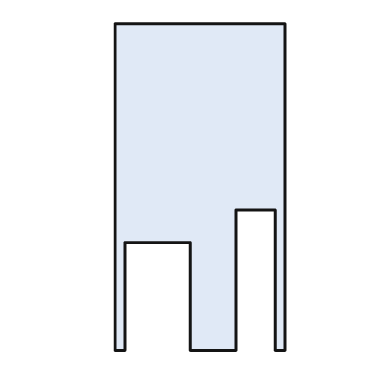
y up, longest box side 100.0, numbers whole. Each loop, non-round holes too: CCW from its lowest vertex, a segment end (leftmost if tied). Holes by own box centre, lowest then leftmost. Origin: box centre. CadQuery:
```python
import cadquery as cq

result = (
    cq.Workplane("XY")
    .moveTo(-26.0, -50.0)
    .lineTo(-23.0, -50.0)
    .lineTo(-23.0, -17.0)
    .lineTo(-3.0, -17.0)
    .lineTo(-3.0, -50.0)
    .lineTo(11.0, -50.0)
    .lineTo(11.0, -7.0)
    .lineTo(23.0, -7.0)
    .lineTo(23.0, -50.0)
    .lineTo(26.0, -50.0)
    .lineTo(26.0, 50.0)
    .lineTo(-26.0, 50.0)
    .close()
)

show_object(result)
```